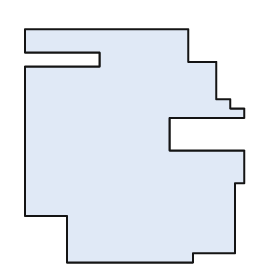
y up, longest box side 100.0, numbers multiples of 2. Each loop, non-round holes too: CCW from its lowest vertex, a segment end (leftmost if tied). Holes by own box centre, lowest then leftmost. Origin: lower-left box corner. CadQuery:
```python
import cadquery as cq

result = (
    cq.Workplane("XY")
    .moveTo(18.0, 0.0)
    .lineTo(72.0, 0.0)
    .lineTo(72.0, 4.0)
    .lineTo(90.0, 4.0)
    .lineTo(90.0, 34.0)
    .lineTo(94.0, 34.0)
    .lineTo(94.0, 48.0)
    .lineTo(62.0, 48.0)
    .lineTo(62.0, 62.0)
    .lineTo(94.0, 62.0)
    .lineTo(94.0, 66.0)
    .lineTo(88.0, 66.0)
    .lineTo(88.0, 70.0)
    .lineTo(82.0, 70.0)
    .lineTo(82.0, 86.0)
    .lineTo(70.0, 86.0)
    .lineTo(70.0, 100.0)
    .lineTo(0.0, 100.0)
    .lineTo(0.0, 90.0)
    .lineTo(32.0, 90.0)
    .lineTo(32.0, 84.0)
    .lineTo(0.0, 84.0)
    .lineTo(0.0, 20.0)
    .lineTo(18.0, 20.0)
    .close()
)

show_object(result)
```